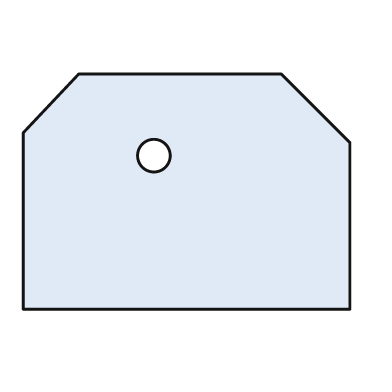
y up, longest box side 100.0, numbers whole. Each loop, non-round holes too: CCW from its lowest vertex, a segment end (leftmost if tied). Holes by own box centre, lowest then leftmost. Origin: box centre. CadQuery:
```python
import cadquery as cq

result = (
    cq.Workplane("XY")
    .moveTo(-50.0, -36.0)
    .lineTo(50.0, -36.0)
    .lineTo(50.0, 15.0)
    .lineTo(29.0, 36.0)
    .lineTo(-33.0, 36.0)
    .lineTo(-50.0, 18.0)
    .close()
    .moveTo(-10.0, 11.0)
    .circle(5.0)
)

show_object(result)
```